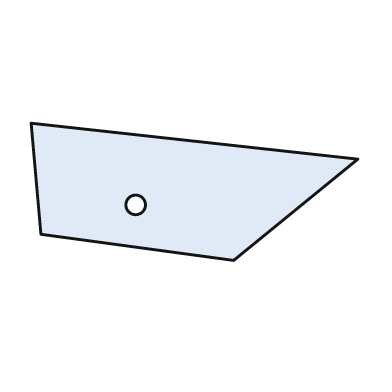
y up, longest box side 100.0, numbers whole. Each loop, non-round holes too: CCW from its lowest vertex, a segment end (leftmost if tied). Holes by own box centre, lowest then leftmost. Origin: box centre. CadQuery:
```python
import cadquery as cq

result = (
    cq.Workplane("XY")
    .moveTo(12.0, -21.0)
    .lineTo(50.0, 10.0)
    .lineTo(-50.0, 21.0)
    .lineTo(-47.0, -13.0)
    .close()
    .moveTo(-18.0, -4.0)
    .circle(3.0)
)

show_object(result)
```